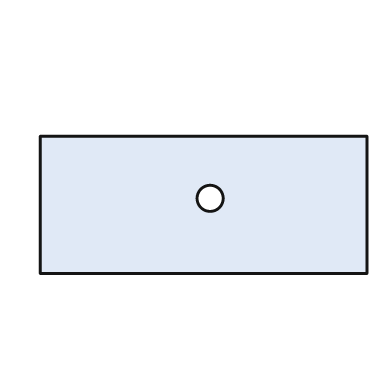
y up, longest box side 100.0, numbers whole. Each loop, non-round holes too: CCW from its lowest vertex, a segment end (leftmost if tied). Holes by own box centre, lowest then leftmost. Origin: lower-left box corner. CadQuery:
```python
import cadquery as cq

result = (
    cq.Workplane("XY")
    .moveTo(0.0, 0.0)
    .lineTo(100.0, 0.0)
    .lineTo(100.0, 42.0)
    .lineTo(0.0, 42.0)
    .close()
    .moveTo(52.0, 23.0)
    .circle(4.0)
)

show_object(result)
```